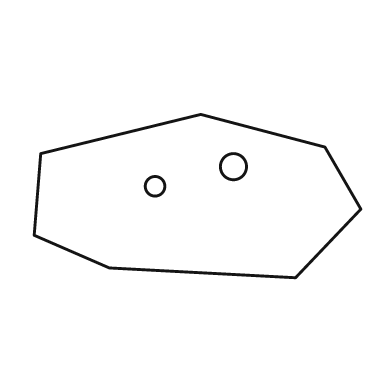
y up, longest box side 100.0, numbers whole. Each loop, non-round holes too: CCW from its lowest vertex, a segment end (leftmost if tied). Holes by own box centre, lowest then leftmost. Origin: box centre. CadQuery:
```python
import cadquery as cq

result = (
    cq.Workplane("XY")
    .moveTo(30.0, -25.0)
    .lineTo(50.0, -4.0)
    .lineTo(39.0, 15.0)
    .lineTo(1.0, 25.0)
    .lineTo(-48.0, 13.0)
    .lineTo(-50.0, -12.0)
    .lineTo(-27.0, -22.0)
    .close()
    .moveTo(-13.0, 3.0)
    .circle(3.0)
    .moveTo(11.0, 9.0)
    .circle(4.0)
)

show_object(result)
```